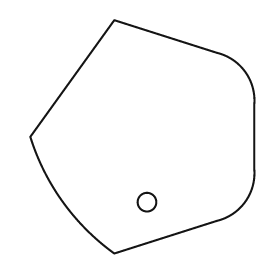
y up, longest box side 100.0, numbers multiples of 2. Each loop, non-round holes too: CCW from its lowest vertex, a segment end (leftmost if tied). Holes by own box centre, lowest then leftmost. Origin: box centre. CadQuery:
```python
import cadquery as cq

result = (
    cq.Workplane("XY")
    .moveTo(-12.0, -50.0)
    .lineTo(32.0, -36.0)
    .threePointArc((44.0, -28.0), (48.0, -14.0))
    .lineTo(48.0, 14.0)
    .threePointArc((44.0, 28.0), (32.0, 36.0))
    .lineTo(-12.0, 50.0)
    .lineTo(-48.0, 0.0)
    .threePointArc((-34.0, -28.0), (-12.0, -50.0))
    .close()
    .moveTo(2.0, -28.0)
    .circle(4.0)
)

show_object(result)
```